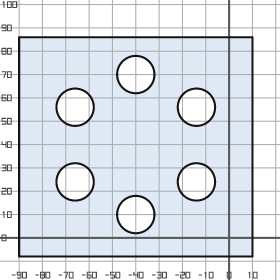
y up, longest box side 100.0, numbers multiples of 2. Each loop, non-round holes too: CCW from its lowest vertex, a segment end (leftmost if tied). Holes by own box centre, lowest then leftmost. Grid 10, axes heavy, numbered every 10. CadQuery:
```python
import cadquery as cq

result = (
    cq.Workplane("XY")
    .moveTo(-90.0, -8.0)
    .lineTo(10.0, -8.0)
    .lineTo(10.0, 86.0)
    .lineTo(-90.0, 86.0)
    .close()
    .moveTo(-40.0, 10.0)
    .circle(8.0)
    .moveTo(-66.0, 24.0)
    .circle(8.0)
    .moveTo(-14.0, 24.0)
    .circle(8.0)
    .moveTo(-66.0, 56.0)
    .circle(8.0)
    .moveTo(-14.0, 56.0)
    .circle(8.0)
    .moveTo(-40.0, 70.0)
    .circle(8.0)
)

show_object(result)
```